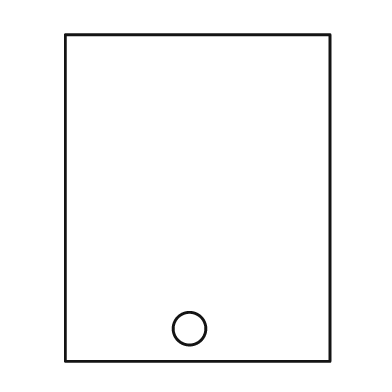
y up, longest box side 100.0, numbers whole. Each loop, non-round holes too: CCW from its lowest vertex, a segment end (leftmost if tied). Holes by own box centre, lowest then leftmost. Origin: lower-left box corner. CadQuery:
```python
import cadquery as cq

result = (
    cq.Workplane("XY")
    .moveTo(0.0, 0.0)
    .lineTo(81.0, 0.0)
    .lineTo(81.0, 100.0)
    .lineTo(0.0, 100.0)
    .close()
    .moveTo(38.0, 10.0)
    .circle(5.0)
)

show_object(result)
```